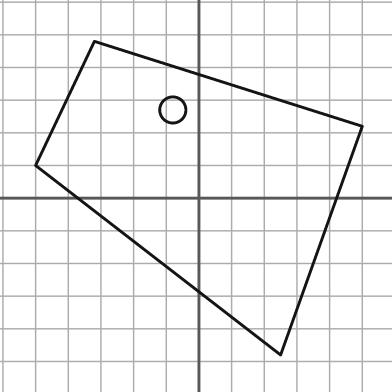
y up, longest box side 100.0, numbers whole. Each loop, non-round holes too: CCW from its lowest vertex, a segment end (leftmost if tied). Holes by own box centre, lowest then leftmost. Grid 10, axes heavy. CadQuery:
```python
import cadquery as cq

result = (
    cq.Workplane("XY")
    .moveTo(25.0, -48.0)
    .lineTo(50.0, 22.0)
    .lineTo(-32.0, 48.0)
    .lineTo(-50.0, 10.0)
    .close()
    .moveTo(-8.0, 27.0)
    .circle(4.0)
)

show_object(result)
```